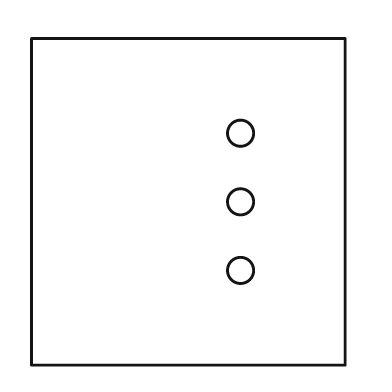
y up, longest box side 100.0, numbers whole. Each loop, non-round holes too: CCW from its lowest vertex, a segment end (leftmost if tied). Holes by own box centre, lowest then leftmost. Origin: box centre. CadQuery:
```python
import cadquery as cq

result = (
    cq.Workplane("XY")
    .moveTo(-48.0, -50.0)
    .lineTo(48.0, -50.0)
    .lineTo(48.0, 50.0)
    .lineTo(-48.0, 50.0)
    .close()
    .moveTo(16.0, -21.0)
    .circle(4.0)
    .moveTo(16.0, 0.0)
    .circle(4.0)
    .moveTo(16.0, 21.0)
    .circle(4.0)
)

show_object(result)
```